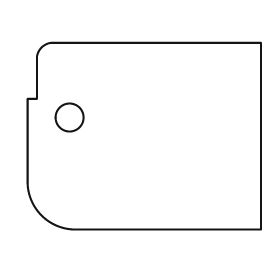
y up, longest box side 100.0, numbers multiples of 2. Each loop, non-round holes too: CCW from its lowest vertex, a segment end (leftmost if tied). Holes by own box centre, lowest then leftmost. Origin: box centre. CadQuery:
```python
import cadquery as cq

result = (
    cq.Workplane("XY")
    .moveTo(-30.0, -40.0)
    .lineTo(50.0, -40.0)
    .lineTo(50.0, 40.0)
    .lineTo(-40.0, 40.0)
    .threePointArc((-44.0, 38.0), (-46.0, 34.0))
    .lineTo(-46.0, 16.0)
    .lineTo(-50.0, 16.0)
    .lineTo(-50.0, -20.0)
    .threePointArc((-44.0, -34.0), (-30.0, -40.0))
    .close()
    .moveTo(-32.0, 8.0)
    .circle(6.0)
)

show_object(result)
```